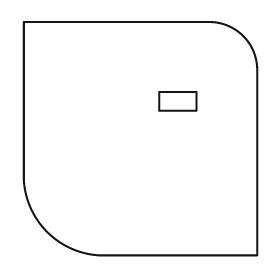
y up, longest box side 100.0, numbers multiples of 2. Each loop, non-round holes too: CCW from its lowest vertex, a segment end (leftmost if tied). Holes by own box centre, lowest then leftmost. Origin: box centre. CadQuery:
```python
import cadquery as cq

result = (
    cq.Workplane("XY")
    .moveTo(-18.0, -50.0)
    .lineTo(50.0, -50.0)
    .lineTo(50.0, 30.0)
    .threePointArc((44.0, 44.0), (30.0, 50.0))
    .lineTo(-50.0, 50.0)
    .lineTo(-50.0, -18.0)
    .threePointArc((-40.0, -40.0), (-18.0, -50.0))
    .close()
    .moveTo(8.0, 12.0)
    .lineTo(24.0, 12.0)
    .lineTo(24.0, 20.0)
    .lineTo(8.0, 20.0)
    .close()
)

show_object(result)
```